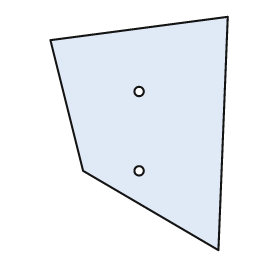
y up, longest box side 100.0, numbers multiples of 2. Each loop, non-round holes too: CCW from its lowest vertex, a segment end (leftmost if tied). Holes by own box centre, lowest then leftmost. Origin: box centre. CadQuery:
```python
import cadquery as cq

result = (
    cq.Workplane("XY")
    .moveTo(34.0, -50.0)
    .lineTo(38.0, 50.0)
    .lineTo(-38.0, 40.0)
    .lineTo(-24.0, -16.0)
    .close()
    .moveTo(0.0, -16.0)
    .circle(2.0)
    .moveTo(0.0, 18.0)
    .circle(2.0)
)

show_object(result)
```